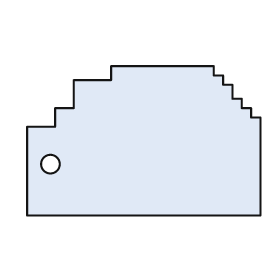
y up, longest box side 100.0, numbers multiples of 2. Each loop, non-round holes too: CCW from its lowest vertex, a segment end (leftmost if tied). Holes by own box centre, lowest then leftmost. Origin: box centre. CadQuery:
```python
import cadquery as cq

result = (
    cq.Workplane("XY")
    .moveTo(-50.0, -32.0)
    .lineTo(50.0, -32.0)
    .lineTo(50.0, 10.0)
    .lineTo(46.0, 10.0)
    .lineTo(46.0, 14.0)
    .lineTo(42.0, 14.0)
    .lineTo(42.0, 18.0)
    .lineTo(38.0, 18.0)
    .lineTo(38.0, 24.0)
    .lineTo(34.0, 24.0)
    .lineTo(34.0, 28.0)
    .lineTo(30.0, 28.0)
    .lineTo(30.0, 32.0)
    .lineTo(-14.0, 32.0)
    .lineTo(-14.0, 26.0)
    .lineTo(-30.0, 26.0)
    .lineTo(-30.0, 14.0)
    .lineTo(-38.0, 14.0)
    .lineTo(-38.0, 6.0)
    .lineTo(-50.0, 6.0)
    .close()
    .moveTo(-40.0, -10.0)
    .circle(4.0)
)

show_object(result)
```